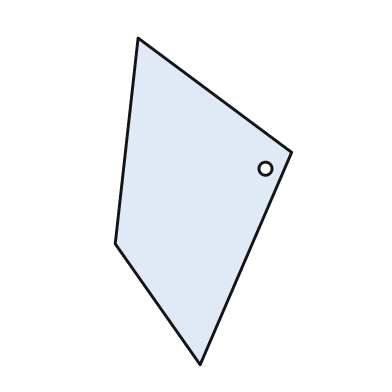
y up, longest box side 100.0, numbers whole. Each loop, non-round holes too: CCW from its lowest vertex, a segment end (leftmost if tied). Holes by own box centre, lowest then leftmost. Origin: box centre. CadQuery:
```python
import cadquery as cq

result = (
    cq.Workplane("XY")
    .moveTo(-1.0, -50.0)
    .lineTo(27.0, 15.0)
    .lineTo(-20.0, 50.0)
    .lineTo(-27.0, -13.0)
    .close()
    .moveTo(19.0, 10.0)
    .circle(2.0)
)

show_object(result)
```